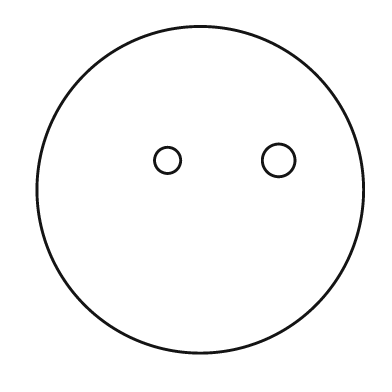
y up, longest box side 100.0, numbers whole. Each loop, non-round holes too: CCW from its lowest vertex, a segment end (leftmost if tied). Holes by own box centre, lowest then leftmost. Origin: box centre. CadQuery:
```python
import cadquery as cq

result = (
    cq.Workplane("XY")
    .moveTo(0.0, 0.0)
    .circle(50.0)
    .moveTo(-10.0, 9.0)
    .circle(4.0)
    .moveTo(24.0, 9.0)
    .circle(5.0)
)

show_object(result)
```